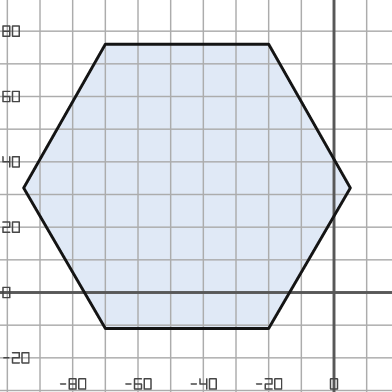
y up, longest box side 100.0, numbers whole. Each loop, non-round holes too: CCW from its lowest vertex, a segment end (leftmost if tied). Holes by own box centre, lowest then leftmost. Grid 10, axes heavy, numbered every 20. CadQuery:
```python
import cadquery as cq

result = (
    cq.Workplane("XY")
    .moveTo(-70.0, -11.0)
    .lineTo(-20.0, -11.0)
    .lineTo(5.0, 32.0)
    .lineTo(-20.0, 76.0)
    .lineTo(-70.0, 76.0)
    .lineTo(-95.0, 32.0)
    .close()
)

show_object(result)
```